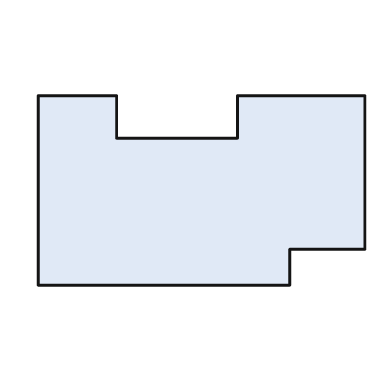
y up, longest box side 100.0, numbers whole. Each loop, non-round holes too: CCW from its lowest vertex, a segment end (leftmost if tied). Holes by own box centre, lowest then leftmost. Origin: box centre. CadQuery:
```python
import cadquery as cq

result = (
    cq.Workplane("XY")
    .moveTo(-50.0, -29.0)
    .lineTo(27.0, -29.0)
    .lineTo(27.0, -18.0)
    .lineTo(50.0, -18.0)
    .lineTo(50.0, 29.0)
    .lineTo(11.0, 29.0)
    .lineTo(11.0, 16.0)
    .lineTo(-26.0, 16.0)
    .lineTo(-26.0, 29.0)
    .lineTo(-50.0, 29.0)
    .close()
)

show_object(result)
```